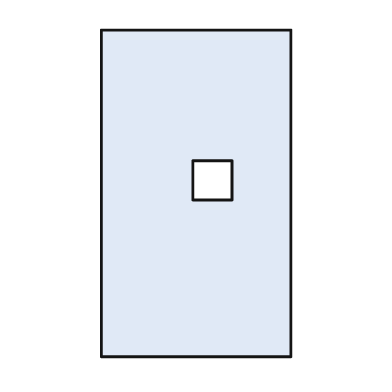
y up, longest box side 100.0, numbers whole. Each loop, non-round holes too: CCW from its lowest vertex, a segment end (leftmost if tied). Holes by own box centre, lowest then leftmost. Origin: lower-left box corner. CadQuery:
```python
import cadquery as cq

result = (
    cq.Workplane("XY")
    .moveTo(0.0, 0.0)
    .lineTo(58.0, 0.0)
    .lineTo(58.0, 100.0)
    .lineTo(0.0, 100.0)
    .close()
    .moveTo(28.0, 48.0)
    .lineTo(40.0, 48.0)
    .lineTo(40.0, 60.0)
    .lineTo(28.0, 60.0)
    .close()
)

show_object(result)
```